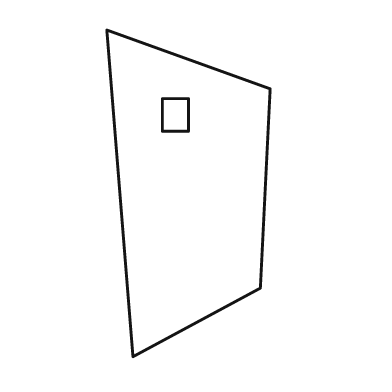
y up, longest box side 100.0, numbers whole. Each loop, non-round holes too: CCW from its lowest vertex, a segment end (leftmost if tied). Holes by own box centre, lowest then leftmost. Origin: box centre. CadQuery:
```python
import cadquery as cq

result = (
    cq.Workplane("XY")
    .moveTo(-17.0, -50.0)
    .lineTo(22.0, -29.0)
    .lineTo(25.0, 32.0)
    .lineTo(-25.0, 50.0)
    .close()
    .moveTo(-8.0, 19.0)
    .lineTo(0.0, 19.0)
    .lineTo(0.0, 29.0)
    .lineTo(-8.0, 29.0)
    .close()
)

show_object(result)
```